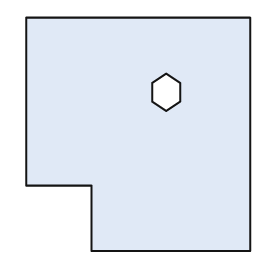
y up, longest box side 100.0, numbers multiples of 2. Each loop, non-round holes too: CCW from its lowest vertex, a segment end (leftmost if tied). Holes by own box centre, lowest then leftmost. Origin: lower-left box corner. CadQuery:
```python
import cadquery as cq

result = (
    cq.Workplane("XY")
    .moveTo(28.0, 0.0)
    .lineTo(96.0, 0.0)
    .lineTo(96.0, 100.0)
    .lineTo(0.0, 100.0)
    .lineTo(0.0, 28.0)
    .lineTo(28.0, 28.0)
    .close()
    .moveTo(60.0, 60.0)
    .lineTo(66.0, 64.0)
    .lineTo(66.0, 72.0)
    .lineTo(60.0, 76.0)
    .lineTo(54.0, 72.0)
    .lineTo(54.0, 64.0)
    .close()
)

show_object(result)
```